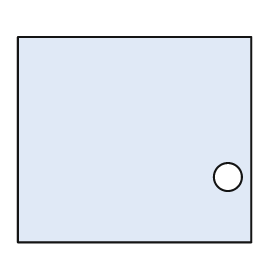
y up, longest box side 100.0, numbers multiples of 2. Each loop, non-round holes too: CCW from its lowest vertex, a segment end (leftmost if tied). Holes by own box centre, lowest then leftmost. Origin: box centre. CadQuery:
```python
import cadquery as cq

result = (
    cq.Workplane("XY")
    .moveTo(-50.0, -44.0)
    .lineTo(50.0, -44.0)
    .lineTo(50.0, 44.0)
    .lineTo(-50.0, 44.0)
    .close()
    .moveTo(40.0, -16.0)
    .circle(6.0)
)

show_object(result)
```